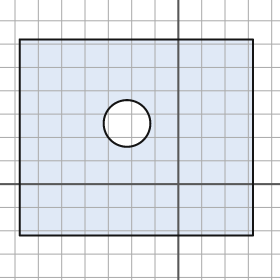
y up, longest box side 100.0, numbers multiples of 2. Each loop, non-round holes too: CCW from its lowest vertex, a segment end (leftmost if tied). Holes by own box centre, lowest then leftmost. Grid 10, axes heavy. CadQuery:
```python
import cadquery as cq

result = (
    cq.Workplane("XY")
    .moveTo(-68.0, -22.0)
    .lineTo(32.0, -22.0)
    .lineTo(32.0, 62.0)
    .lineTo(-68.0, 62.0)
    .close()
    .moveTo(-22.0, 26.0)
    .circle(10.0)
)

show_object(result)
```